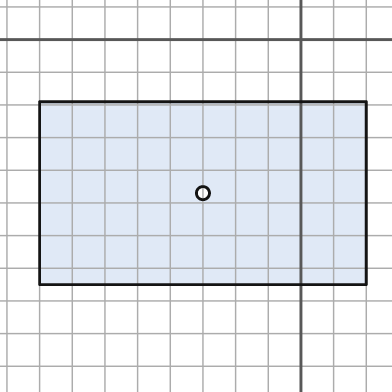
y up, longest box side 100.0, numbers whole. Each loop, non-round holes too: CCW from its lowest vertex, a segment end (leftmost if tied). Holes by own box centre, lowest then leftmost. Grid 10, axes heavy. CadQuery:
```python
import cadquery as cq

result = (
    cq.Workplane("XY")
    .moveTo(-80.0, -75.0)
    .lineTo(20.0, -75.0)
    .lineTo(20.0, -19.0)
    .lineTo(-80.0, -19.0)
    .close()
    .moveTo(-30.0, -47.0)
    .circle(2.0)
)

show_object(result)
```